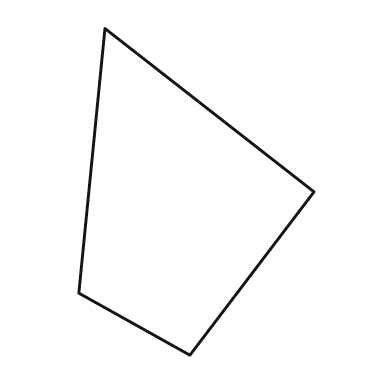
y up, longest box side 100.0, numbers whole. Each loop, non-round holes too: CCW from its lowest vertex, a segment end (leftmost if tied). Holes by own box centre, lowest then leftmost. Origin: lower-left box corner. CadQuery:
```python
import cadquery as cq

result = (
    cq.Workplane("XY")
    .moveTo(34.0, 0.0)
    .lineTo(72.0, 50.0)
    .lineTo(8.0, 100.0)
    .lineTo(0.0, 19.0)
    .close()
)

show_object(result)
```